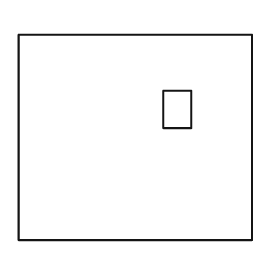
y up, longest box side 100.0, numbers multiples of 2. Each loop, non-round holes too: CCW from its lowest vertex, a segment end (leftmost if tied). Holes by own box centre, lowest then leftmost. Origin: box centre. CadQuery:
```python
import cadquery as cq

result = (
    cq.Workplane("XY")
    .moveTo(-50.0, -44.0)
    .lineTo(50.0, -44.0)
    .lineTo(50.0, 44.0)
    .lineTo(-50.0, 44.0)
    .close()
    .moveTo(12.0, 4.0)
    .lineTo(24.0, 4.0)
    .lineTo(24.0, 20.0)
    .lineTo(12.0, 20.0)
    .close()
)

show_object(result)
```